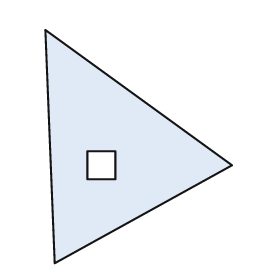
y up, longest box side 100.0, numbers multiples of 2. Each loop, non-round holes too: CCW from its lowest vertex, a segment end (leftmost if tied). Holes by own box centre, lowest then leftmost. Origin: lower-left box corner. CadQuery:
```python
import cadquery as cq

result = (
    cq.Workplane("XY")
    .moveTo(4.0, 0.0)
    .lineTo(80.0, 42.0)
    .lineTo(0.0, 100.0)
    .close()
    .moveTo(18.0, 36.0)
    .lineTo(30.0, 36.0)
    .lineTo(30.0, 48.0)
    .lineTo(18.0, 48.0)
    .close()
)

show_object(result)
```